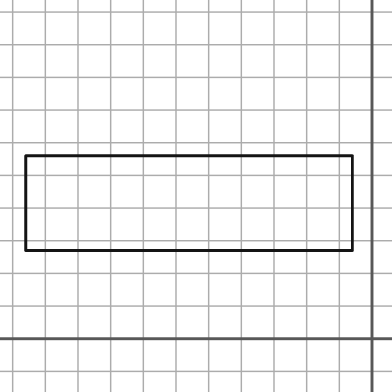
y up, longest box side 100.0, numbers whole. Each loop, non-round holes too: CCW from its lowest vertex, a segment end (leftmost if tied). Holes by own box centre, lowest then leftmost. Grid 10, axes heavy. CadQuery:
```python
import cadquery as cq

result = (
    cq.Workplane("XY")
    .moveTo(-106.0, 27.0)
    .lineTo(-6.0, 27.0)
    .lineTo(-6.0, 56.0)
    .lineTo(-106.0, 56.0)
    .close()
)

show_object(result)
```